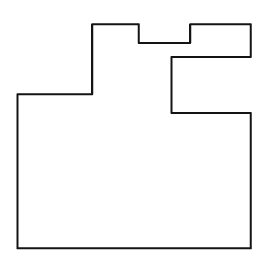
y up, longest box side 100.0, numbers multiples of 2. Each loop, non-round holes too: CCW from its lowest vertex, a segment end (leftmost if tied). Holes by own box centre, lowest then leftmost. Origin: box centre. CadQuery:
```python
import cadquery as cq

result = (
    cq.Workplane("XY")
    .moveTo(-50.0, -48.0)
    .lineTo(50.0, -48.0)
    .lineTo(50.0, 10.0)
    .lineTo(16.0, 10.0)
    .lineTo(16.0, 34.0)
    .lineTo(50.0, 34.0)
    .lineTo(50.0, 48.0)
    .lineTo(24.0, 48.0)
    .lineTo(24.0, 40.0)
    .lineTo(2.0, 40.0)
    .lineTo(2.0, 48.0)
    .lineTo(-18.0, 48.0)
    .lineTo(-18.0, 18.0)
    .lineTo(-50.0, 18.0)
    .close()
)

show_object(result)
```